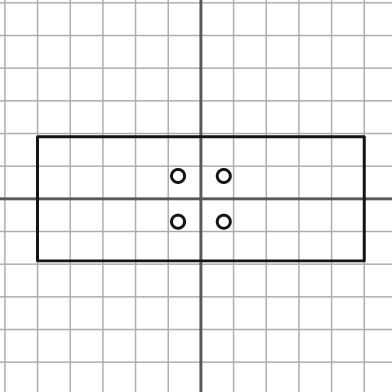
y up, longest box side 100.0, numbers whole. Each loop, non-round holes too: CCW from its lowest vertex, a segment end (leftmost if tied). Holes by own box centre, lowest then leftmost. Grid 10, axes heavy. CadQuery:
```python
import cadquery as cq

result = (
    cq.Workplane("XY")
    .moveTo(-50.0, -19.0)
    .lineTo(50.0, -19.0)
    .lineTo(50.0, 19.0)
    .lineTo(-50.0, 19.0)
    .close()
    .moveTo(-7.0, -7.0)
    .circle(2.0)
    .moveTo(7.0, -7.0)
    .circle(2.0)
    .moveTo(-7.0, 7.0)
    .circle(2.0)
    .moveTo(7.0, 7.0)
    .circle(2.0)
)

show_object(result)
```